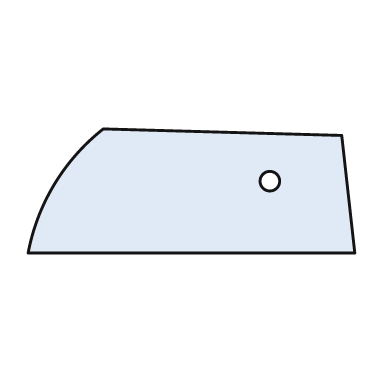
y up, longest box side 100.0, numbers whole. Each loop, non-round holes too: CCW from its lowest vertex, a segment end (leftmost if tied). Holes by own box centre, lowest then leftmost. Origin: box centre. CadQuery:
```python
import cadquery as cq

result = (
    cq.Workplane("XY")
    .moveTo(-50.0, -19.0)
    .lineTo(50.0, -19.0)
    .lineTo(46.0, 17.0)
    .lineTo(-27.0, 19.0)
    .threePointArc((-42.0, 2.0), (-50.0, -19.0))
    .close()
    .moveTo(24.0, 3.0)
    .circle(3.0)
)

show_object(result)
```